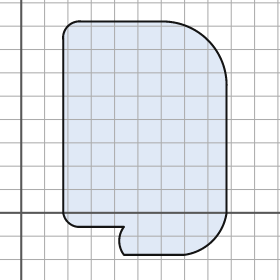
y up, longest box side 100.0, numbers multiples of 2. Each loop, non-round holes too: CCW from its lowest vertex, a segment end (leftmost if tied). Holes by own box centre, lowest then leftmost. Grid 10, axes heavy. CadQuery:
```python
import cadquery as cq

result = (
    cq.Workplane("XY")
    .moveTo(44.0, -18.0)
    .lineTo(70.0, -18.0)
    .threePointArc((82.0, -12.0), (88.0, 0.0))
    .lineTo(88.0, 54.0)
    .threePointArc((80.0, 74.0), (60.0, 82.0))
    .lineTo(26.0, 82.0)
    .threePointArc((20.0, 80.0), (18.0, 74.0))
    .lineTo(18.0, 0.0)
    .threePointArc((20.0, -4.0), (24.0, -6.0))
    .lineTo(44.0, -6.0)
    .threePointArc((42.0, -12.0), (44.0, -18.0))
    .close()
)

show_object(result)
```